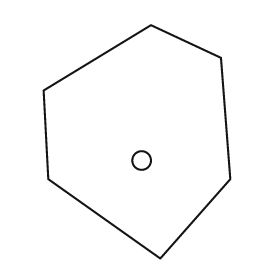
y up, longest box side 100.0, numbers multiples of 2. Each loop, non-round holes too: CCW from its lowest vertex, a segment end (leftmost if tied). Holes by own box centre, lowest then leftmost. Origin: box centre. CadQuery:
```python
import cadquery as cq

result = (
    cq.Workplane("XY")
    .moveTo(10.0, -50.0)
    .lineTo(40.0, -16.0)
    .lineTo(36.0, 36.0)
    .lineTo(6.0, 50.0)
    .lineTo(-40.0, 22.0)
    .lineTo(-38.0, -16.0)
    .close()
    .moveTo(2.0, -8.0)
    .circle(4.0)
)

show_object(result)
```